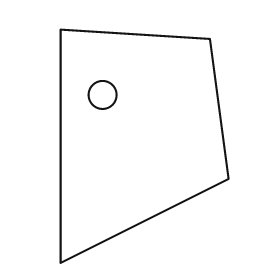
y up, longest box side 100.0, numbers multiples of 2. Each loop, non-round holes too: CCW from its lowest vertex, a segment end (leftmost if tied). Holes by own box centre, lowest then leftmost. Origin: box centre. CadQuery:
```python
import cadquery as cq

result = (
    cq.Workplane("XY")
    .moveTo(-36.0, -50.0)
    .lineTo(36.0, -14.0)
    .lineTo(28.0, 46.0)
    .lineTo(-36.0, 50.0)
    .close()
    .moveTo(-18.0, 22.0)
    .circle(6.0)
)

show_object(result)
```